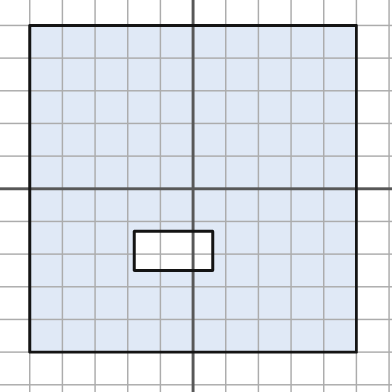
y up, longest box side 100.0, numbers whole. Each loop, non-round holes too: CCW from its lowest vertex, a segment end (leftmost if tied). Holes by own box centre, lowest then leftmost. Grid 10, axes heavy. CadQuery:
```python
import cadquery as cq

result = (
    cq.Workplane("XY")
    .moveTo(-50.0, -50.0)
    .lineTo(50.0, -50.0)
    .lineTo(50.0, 50.0)
    .lineTo(-50.0, 50.0)
    .close()
    .moveTo(-18.0, -25.0)
    .lineTo(6.0, -25.0)
    .lineTo(6.0, -13.0)
    .lineTo(-18.0, -13.0)
    .close()
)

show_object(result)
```